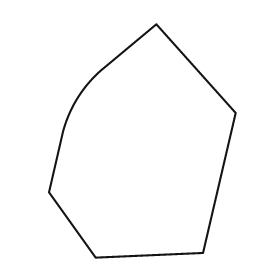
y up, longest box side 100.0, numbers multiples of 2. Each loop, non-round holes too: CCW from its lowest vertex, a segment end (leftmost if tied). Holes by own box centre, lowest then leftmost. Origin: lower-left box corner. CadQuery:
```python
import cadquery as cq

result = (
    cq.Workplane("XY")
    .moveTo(20.0, 0.0)
    .lineTo(66.0, 2.0)
    .lineTo(80.0, 62.0)
    .lineTo(46.0, 100.0)
    .lineTo(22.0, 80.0)
    .threePointArc((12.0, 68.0), (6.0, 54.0))
    .lineTo(0.0, 28.0)
    .close()
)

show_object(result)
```